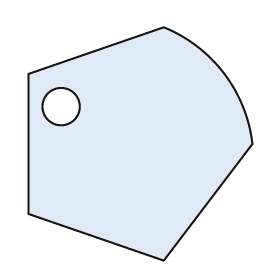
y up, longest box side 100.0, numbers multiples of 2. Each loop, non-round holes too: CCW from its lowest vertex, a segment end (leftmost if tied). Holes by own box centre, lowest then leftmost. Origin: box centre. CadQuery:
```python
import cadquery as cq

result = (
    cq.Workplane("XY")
    .moveTo(10.0, -50.0)
    .lineTo(48.0, 0.0)
    .threePointArc((36.0, 30.0), (10.0, 50.0))
    .lineTo(-48.0, 30.0)
    .lineTo(-48.0, -30.0)
    .close()
    .moveTo(-34.0, 16.0)
    .circle(8.0)
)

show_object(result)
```